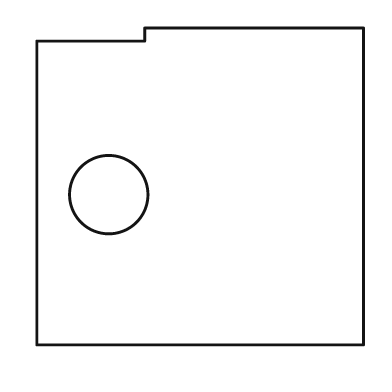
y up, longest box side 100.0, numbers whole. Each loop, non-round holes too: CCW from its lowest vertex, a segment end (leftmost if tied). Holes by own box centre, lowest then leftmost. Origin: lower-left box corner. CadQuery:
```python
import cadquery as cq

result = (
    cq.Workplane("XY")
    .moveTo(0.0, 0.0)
    .lineTo(100.0, 0.0)
    .lineTo(100.0, 97.0)
    .lineTo(33.0, 97.0)
    .lineTo(33.0, 93.0)
    .lineTo(0.0, 93.0)
    .close()
    .moveTo(22.0, 46.0)
    .circle(12.0)
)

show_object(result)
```